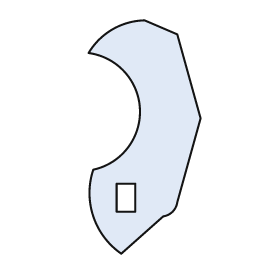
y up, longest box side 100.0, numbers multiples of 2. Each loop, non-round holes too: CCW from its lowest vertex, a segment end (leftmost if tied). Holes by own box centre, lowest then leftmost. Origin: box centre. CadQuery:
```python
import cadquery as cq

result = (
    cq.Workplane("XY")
    .moveTo(-10.0, -50.0)
    .lineTo(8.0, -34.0)
    .threePointArc((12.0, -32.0), (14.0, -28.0))
    .lineTo(24.0, 8.0)
    .lineTo(14.0, 44.0)
    .lineTo(0.0, 50.0)
    .threePointArc((-14.0, 46.0), (-24.0, 36.0))
    .threePointArc((-2.0, 12.0), (-22.0, -14.0))
    .threePointArc((-22.0, -34.0), (-10.0, -50.0))
    .close()
    .moveTo(-12.0, -32.0)
    .lineTo(-4.0, -32.0)
    .lineTo(-4.0, -20.0)
    .lineTo(-12.0, -20.0)
    .close()
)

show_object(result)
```